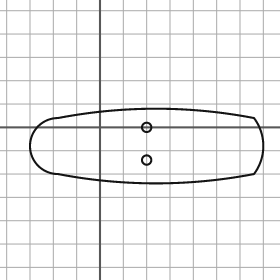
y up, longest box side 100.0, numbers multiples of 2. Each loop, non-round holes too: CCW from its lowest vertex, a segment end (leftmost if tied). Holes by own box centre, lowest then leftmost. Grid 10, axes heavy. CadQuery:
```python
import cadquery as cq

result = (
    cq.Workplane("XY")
    .moveTo(-18.0, -20.0)
    .threePointArc((24.0, -24.0), (66.0, -20.0))
    .threePointArc((70.0, -8.0), (66.0, 4.0))
    .threePointArc((24.0, 8.0), (-18.0, 4.0))
    .threePointArc((-30.0, -8.0), (-18.0, -20.0))
    .close()
    .moveTo(20.0, -14.0)
    .circle(2.0)
    .moveTo(20.0, 0.0)
    .circle(2.0)
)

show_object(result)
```